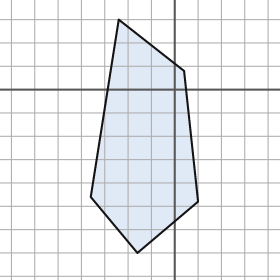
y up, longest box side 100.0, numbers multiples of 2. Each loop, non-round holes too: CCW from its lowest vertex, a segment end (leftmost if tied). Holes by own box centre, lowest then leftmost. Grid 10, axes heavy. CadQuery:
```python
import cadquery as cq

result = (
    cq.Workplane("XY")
    .moveTo(-16.0, -70.0)
    .lineTo(10.0, -48.0)
    .lineTo(4.0, 8.0)
    .lineTo(-24.0, 30.0)
    .lineTo(-36.0, -46.0)
    .close()
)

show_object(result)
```